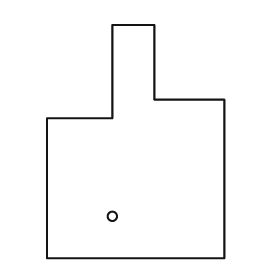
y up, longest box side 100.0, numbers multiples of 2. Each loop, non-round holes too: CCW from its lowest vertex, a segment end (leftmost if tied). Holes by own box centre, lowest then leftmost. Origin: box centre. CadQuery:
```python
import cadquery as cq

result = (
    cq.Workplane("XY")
    .moveTo(-38.0, -50.0)
    .lineTo(38.0, -50.0)
    .lineTo(38.0, 18.0)
    .lineTo(8.0, 18.0)
    .lineTo(8.0, 50.0)
    .lineTo(-10.0, 50.0)
    .lineTo(-10.0, 10.0)
    .lineTo(-38.0, 10.0)
    .close()
    .moveTo(-10.0, -32.0)
    .circle(2.0)
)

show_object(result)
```